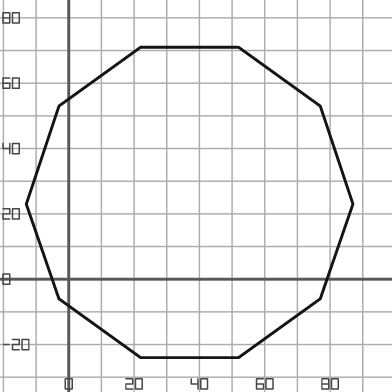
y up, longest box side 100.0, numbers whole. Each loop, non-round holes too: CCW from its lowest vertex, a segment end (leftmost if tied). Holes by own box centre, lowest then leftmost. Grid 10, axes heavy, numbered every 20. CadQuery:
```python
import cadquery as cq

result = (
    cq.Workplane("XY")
    .moveTo(22.0, -24.0)
    .lineTo(52.0, -24.0)
    .lineTo(77.0, -6.0)
    .lineTo(87.0, 23.0)
    .lineTo(77.0, 53.0)
    .lineTo(52.0, 71.0)
    .lineTo(22.0, 71.0)
    .lineTo(-3.0, 53.0)
    .lineTo(-13.0, 23.0)
    .lineTo(-3.0, -6.0)
    .close()
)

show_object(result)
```